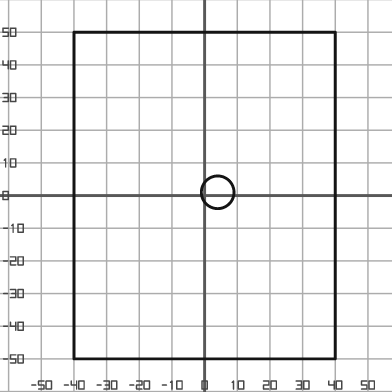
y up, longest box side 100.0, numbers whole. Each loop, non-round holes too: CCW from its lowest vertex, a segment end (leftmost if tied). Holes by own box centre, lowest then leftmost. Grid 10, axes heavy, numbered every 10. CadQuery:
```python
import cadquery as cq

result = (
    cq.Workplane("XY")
    .moveTo(-40.0, -50.0)
    .lineTo(40.0, -50.0)
    .lineTo(40.0, 50.0)
    .lineTo(-40.0, 50.0)
    .close()
    .moveTo(4.0, 1.0)
    .circle(5.0)
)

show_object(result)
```